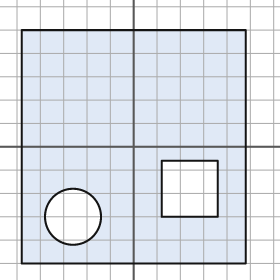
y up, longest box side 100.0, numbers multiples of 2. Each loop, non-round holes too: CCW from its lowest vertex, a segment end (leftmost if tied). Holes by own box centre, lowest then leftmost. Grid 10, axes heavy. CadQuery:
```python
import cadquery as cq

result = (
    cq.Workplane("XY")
    .moveTo(-48.0, -50.0)
    .lineTo(48.0, -50.0)
    .lineTo(48.0, 50.0)
    .lineTo(-48.0, 50.0)
    .close()
    .moveTo(-26.0, -30.0)
    .circle(12.0)
    .moveTo(12.0, -30.0)
    .lineTo(36.0, -30.0)
    .lineTo(36.0, -6.0)
    .lineTo(12.0, -6.0)
    .close()
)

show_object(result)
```